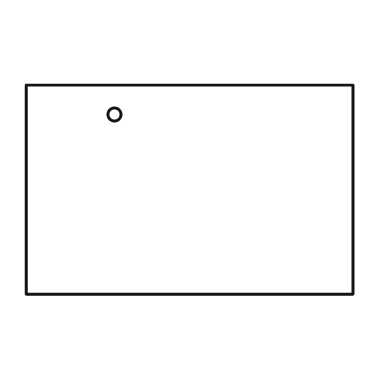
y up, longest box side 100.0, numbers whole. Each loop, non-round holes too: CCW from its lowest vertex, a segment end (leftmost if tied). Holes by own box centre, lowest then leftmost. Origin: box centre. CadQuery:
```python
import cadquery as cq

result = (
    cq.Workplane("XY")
    .moveTo(-50.0, -32.0)
    .lineTo(50.0, -32.0)
    .lineTo(50.0, 32.0)
    .lineTo(-50.0, 32.0)
    .close()
    .moveTo(-23.0, 23.0)
    .circle(2.0)
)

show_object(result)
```